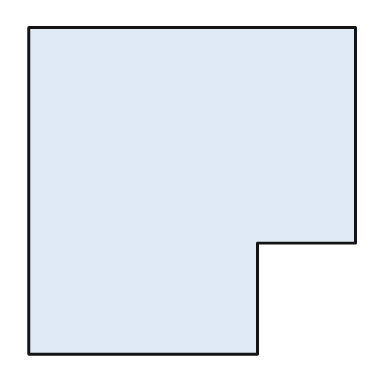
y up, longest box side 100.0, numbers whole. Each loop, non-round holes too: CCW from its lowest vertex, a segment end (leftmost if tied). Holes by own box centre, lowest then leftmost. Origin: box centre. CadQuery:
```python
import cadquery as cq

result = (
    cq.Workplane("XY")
    .moveTo(-50.0, -50.0)
    .lineTo(20.0, -50.0)
    .lineTo(20.0, -16.0)
    .lineTo(50.0, -16.0)
    .lineTo(50.0, 50.0)
    .lineTo(-50.0, 50.0)
    .close()
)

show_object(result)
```